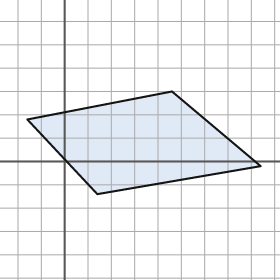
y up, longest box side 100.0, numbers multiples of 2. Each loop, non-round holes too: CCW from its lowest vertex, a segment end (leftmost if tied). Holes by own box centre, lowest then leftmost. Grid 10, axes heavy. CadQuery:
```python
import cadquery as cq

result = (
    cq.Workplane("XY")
    .moveTo(14.0, -14.0)
    .lineTo(84.0, -2.0)
    .lineTo(46.0, 30.0)
    .lineTo(-16.0, 18.0)
    .close()
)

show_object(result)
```